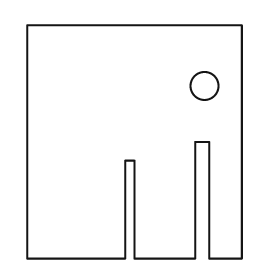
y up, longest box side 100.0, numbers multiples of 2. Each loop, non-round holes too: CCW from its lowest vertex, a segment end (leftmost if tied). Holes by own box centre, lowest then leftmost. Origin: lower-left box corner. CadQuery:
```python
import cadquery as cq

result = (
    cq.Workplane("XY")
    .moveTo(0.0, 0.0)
    .lineTo(42.0, 0.0)
    .lineTo(42.0, 42.0)
    .lineTo(46.0, 42.0)
    .lineTo(46.0, 0.0)
    .lineTo(72.0, 0.0)
    .lineTo(72.0, 50.0)
    .lineTo(78.0, 50.0)
    .lineTo(78.0, 0.0)
    .lineTo(92.0, 0.0)
    .lineTo(92.0, 100.0)
    .lineTo(0.0, 100.0)
    .close()
    .moveTo(76.0, 74.0)
    .circle(6.0)
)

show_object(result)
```